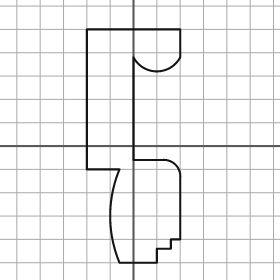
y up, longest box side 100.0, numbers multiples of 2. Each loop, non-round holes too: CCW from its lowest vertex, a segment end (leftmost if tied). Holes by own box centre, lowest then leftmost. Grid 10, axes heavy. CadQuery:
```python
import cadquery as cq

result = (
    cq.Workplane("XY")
    .moveTo(-6.0, -50.0)
    .lineTo(10.0, -50.0)
    .lineTo(10.0, -44.0)
    .lineTo(16.0, -44.0)
    .lineTo(16.0, -40.0)
    .lineTo(20.0, -40.0)
    .lineTo(20.0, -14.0)
    .threePointArc((18.0, -8.0), (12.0, -6.0))
    .lineTo(0.0, -6.0)
    .lineTo(0.0, 38.0)
    .threePointArc((10.0, 32.0), (20.0, 38.0))
    .lineTo(20.0, 50.0)
    .lineTo(-20.0, 50.0)
    .lineTo(-20.0, -10.0)
    .lineTo(-6.0, -10.0)
    .threePointArc((-10.0, -30.0), (-6.0, -50.0))
    .close()
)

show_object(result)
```